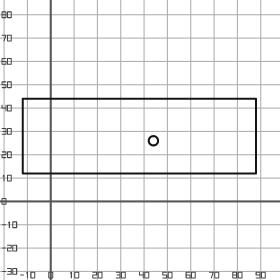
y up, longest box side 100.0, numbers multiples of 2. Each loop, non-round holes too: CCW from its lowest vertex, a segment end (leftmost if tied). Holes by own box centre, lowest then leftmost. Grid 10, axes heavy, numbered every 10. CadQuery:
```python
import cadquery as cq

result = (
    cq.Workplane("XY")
    .moveTo(-12.0, 12.0)
    .lineTo(88.0, 12.0)
    .lineTo(88.0, 44.0)
    .lineTo(-12.0, 44.0)
    .close()
    .moveTo(44.0, 26.0)
    .circle(2.0)
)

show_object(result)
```